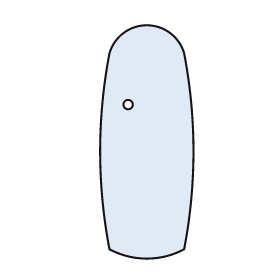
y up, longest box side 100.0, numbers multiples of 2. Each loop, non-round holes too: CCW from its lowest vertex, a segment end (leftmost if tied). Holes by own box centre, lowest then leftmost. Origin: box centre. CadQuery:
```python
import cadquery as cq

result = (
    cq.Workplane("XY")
    .moveTo(-16.0, -46.0)
    .threePointArc((0.0, -50.0), (16.0, -46.0))
    .threePointArc((20.0, -4.0), (16.0, 38.0))
    .threePointArc((0.0, 50.0), (-16.0, 38.0))
    .threePointArc((-20.0, -4.0), (-16.0, -46.0))
    .close()
    .moveTo(-8.0, 16.0)
    .circle(2.0)
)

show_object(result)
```